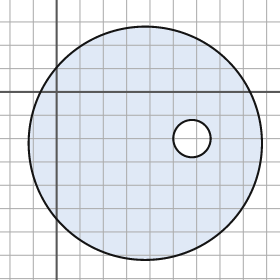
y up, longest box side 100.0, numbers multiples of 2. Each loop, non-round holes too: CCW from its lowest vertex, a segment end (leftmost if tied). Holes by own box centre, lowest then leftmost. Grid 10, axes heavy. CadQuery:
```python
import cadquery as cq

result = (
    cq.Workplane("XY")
    .moveTo(38.0, -22.0)
    .circle(50.0)
    .moveTo(58.0, -20.0)
    .circle(8.0)
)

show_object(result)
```